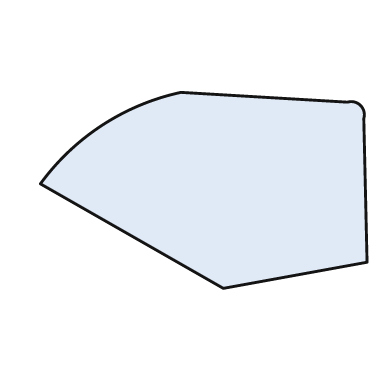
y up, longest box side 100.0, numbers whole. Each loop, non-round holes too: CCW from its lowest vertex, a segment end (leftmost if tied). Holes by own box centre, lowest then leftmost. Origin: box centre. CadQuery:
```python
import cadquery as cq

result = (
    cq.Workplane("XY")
    .moveTo(6.0, -30.0)
    .lineTo(50.0, -22.0)
    .lineTo(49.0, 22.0)
    .threePointArc((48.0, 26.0), (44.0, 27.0))
    .lineTo(-7.0, 30.0)
    .threePointArc((-31.0, 20.0), (-50.0, 2.0))
    .close()
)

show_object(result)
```